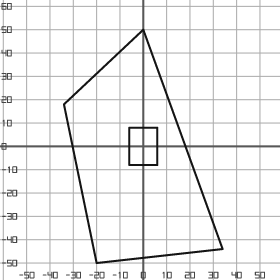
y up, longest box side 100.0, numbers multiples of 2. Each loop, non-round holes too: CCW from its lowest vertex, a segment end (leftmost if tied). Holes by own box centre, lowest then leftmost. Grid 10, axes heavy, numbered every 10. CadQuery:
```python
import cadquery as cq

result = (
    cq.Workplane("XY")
    .moveTo(-20.0, -50.0)
    .lineTo(34.0, -44.0)
    .lineTo(0.0, 50.0)
    .lineTo(-34.0, 18.0)
    .close()
    .moveTo(-6.0, -8.0)
    .lineTo(6.0, -8.0)
    .lineTo(6.0, 8.0)
    .lineTo(-6.0, 8.0)
    .close()
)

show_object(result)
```